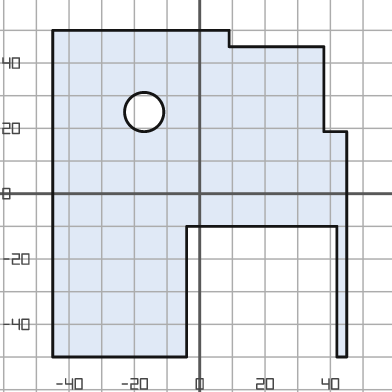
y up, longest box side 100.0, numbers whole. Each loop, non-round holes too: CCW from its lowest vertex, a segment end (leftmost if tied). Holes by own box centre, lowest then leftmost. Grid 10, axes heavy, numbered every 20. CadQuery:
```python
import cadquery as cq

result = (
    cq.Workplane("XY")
    .moveTo(-45.0, -50.0)
    .lineTo(-4.0, -50.0)
    .lineTo(-4.0, -10.0)
    .lineTo(42.0, -10.0)
    .lineTo(42.0, -50.0)
    .lineTo(45.0, -50.0)
    .lineTo(45.0, 19.0)
    .lineTo(38.0, 19.0)
    .lineTo(38.0, 45.0)
    .lineTo(9.0, 45.0)
    .lineTo(9.0, 50.0)
    .lineTo(-45.0, 50.0)
    .close()
    .moveTo(-17.0, 25.0)
    .circle(6.0)
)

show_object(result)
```